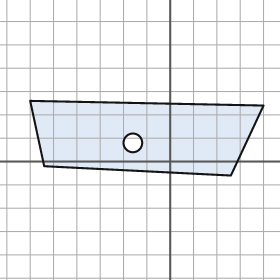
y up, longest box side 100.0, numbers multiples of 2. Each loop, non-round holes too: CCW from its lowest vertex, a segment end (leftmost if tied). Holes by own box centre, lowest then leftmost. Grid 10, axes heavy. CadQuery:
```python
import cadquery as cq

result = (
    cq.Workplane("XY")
    .moveTo(26.0, -6.0)
    .lineTo(40.0, 24.0)
    .lineTo(-60.0, 26.0)
    .lineTo(-54.0, -2.0)
    .close()
    .moveTo(-16.0, 8.0)
    .circle(4.0)
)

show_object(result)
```